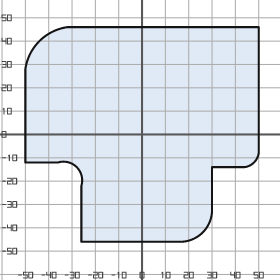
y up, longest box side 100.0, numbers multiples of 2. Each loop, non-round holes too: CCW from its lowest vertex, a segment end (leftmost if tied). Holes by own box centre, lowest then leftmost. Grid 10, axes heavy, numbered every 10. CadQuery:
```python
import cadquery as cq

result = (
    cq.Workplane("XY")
    .moveTo(-26.0, -46.0)
    .lineTo(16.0, -46.0)
    .threePointArc((26.0, -42.0), (30.0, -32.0))
    .lineTo(30.0, -14.0)
    .lineTo(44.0, -14.0)
    .threePointArc((48.0, -12.0), (50.0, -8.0))
    .lineTo(50.0, 46.0)
    .lineTo(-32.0, 46.0)
    .threePointArc((-44.0, 40.0), (-50.0, 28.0))
    .lineTo(-50.0, -12.0)
    .lineTo(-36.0, -12.0)
    .threePointArc((-28.0, -14.0), (-26.0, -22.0))
    .close()
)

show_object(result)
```